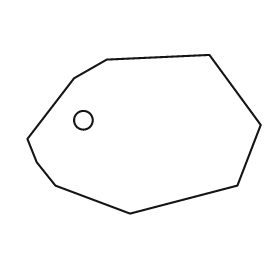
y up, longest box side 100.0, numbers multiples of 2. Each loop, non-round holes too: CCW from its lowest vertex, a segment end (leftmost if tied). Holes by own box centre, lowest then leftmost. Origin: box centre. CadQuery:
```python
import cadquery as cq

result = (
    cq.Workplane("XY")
    .moveTo(-6.0, -34.0)
    .lineTo(40.0, -22.0)
    .lineTo(50.0, 4.0)
    .lineTo(28.0, 34.0)
    .lineTo(-16.0, 32.0)
    .lineTo(-30.0, 24.0)
    .lineTo(-50.0, -2.0)
    .lineTo(-46.0, -12.0)
    .lineTo(-38.0, -22.0)
    .close()
    .moveTo(-26.0, 6.0)
    .circle(4.0)
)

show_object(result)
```